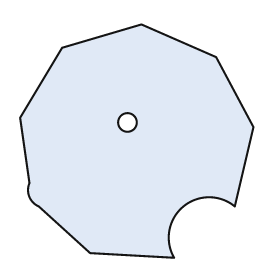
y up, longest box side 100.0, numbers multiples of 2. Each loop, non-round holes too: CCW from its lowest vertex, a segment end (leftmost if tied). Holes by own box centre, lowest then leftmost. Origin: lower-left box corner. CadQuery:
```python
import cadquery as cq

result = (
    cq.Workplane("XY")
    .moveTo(66.0, 0.0)
    .threePointArc((70.0, 22.0), (92.0, 22.0))
    .lineTo(100.0, 56.0)
    .lineTo(84.0, 86.0)
    .lineTo(52.0, 100.0)
    .lineTo(18.0, 90.0)
    .lineTo(0.0, 60.0)
    .lineTo(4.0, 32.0)
    .threePointArc((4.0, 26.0), (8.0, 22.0))
    .lineTo(30.0, 2.0)
    .close()
    .moveTo(46.0, 58.0)
    .circle(4.0)
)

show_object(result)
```